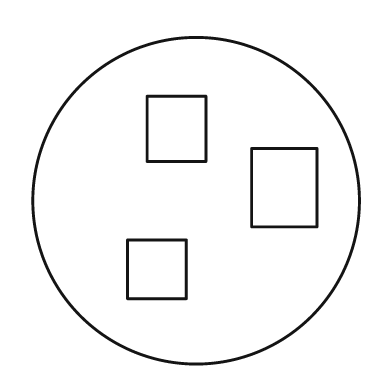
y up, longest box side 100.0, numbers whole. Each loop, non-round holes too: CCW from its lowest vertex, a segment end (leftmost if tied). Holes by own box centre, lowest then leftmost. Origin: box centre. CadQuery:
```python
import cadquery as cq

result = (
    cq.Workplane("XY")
    .moveTo(0.0, 0.0)
    .circle(50.0)
    .moveTo(-21.0, -30.0)
    .lineTo(-3.0, -30.0)
    .lineTo(-3.0, -12.0)
    .lineTo(-21.0, -12.0)
    .close()
    .moveTo(17.0, -8.0)
    .lineTo(37.0, -8.0)
    .lineTo(37.0, 16.0)
    .lineTo(17.0, 16.0)
    .close()
    .moveTo(-15.0, 12.0)
    .lineTo(3.0, 12.0)
    .lineTo(3.0, 32.0)
    .lineTo(-15.0, 32.0)
    .close()
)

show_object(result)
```